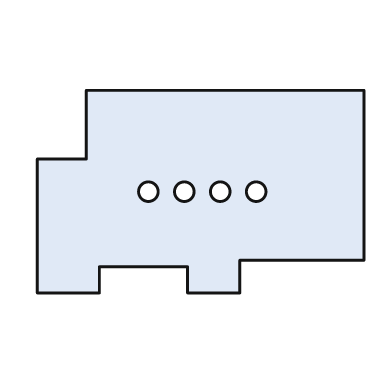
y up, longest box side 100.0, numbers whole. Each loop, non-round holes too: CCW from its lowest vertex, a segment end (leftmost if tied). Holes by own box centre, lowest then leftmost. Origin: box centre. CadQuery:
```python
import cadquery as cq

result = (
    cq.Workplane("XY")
    .moveTo(-50.0, -31.0)
    .lineTo(-31.0, -31.0)
    .lineTo(-31.0, -23.0)
    .lineTo(-4.0, -23.0)
    .lineTo(-4.0, -31.0)
    .lineTo(12.0, -31.0)
    .lineTo(12.0, -21.0)
    .lineTo(50.0, -21.0)
    .lineTo(50.0, 31.0)
    .lineTo(-35.0, 31.0)
    .lineTo(-35.0, 10.0)
    .lineTo(-50.0, 10.0)
    .close()
    .moveTo(-16.0, 0.0)
    .circle(3.0)
    .moveTo(-5.0, 0.0)
    .circle(3.0)
    .moveTo(6.0, 0.0)
    .circle(3.0)
    .moveTo(17.0, 0.0)
    .circle(3.0)
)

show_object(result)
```